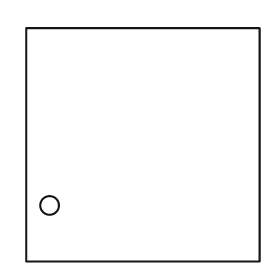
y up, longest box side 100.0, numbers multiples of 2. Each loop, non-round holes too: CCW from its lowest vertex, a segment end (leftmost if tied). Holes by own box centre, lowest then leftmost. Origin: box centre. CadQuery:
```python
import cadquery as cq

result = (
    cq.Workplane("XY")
    .moveTo(-50.0, -50.0)
    .lineTo(50.0, -50.0)
    .lineTo(50.0, 50.0)
    .lineTo(-50.0, 50.0)
    .close()
    .moveTo(-40.0, -26.0)
    .circle(4.0)
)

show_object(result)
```